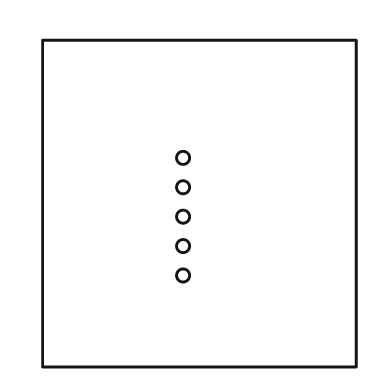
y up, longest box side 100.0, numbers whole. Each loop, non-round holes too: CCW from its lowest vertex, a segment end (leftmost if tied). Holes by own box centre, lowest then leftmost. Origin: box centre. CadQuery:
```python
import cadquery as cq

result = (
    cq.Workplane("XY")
    .moveTo(-48.0, -50.0)
    .lineTo(48.0, -50.0)
    .lineTo(48.0, 50.0)
    .lineTo(-48.0, 50.0)
    .close()
    .moveTo(-5.0, -22.0)
    .circle(2.0)
    .moveTo(-5.0, -13.0)
    .circle(2.0)
    .moveTo(-5.0, -4.0)
    .circle(2.0)
    .moveTo(-5.0, 5.0)
    .circle(2.0)
    .moveTo(-5.0, 14.0)
    .circle(2.0)
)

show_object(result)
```